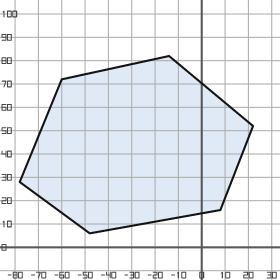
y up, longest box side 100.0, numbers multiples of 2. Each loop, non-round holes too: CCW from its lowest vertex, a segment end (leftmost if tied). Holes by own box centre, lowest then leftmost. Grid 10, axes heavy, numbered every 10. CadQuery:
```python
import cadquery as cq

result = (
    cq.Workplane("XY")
    .moveTo(-48.0, 6.0)
    .lineTo(8.0, 16.0)
    .lineTo(22.0, 52.0)
    .lineTo(-14.0, 82.0)
    .lineTo(-60.0, 72.0)
    .lineTo(-78.0, 28.0)
    .close()
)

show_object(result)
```